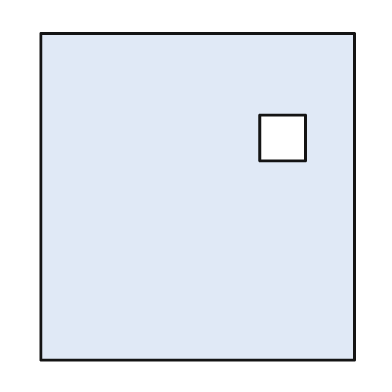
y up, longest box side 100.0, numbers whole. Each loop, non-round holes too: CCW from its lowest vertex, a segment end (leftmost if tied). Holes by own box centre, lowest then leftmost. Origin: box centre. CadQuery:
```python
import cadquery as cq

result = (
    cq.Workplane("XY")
    .moveTo(-48.0, -50.0)
    .lineTo(48.0, -50.0)
    .lineTo(48.0, 50.0)
    .lineTo(-48.0, 50.0)
    .close()
    .moveTo(19.0, 11.0)
    .lineTo(33.0, 11.0)
    .lineTo(33.0, 25.0)
    .lineTo(19.0, 25.0)
    .close()
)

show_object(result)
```